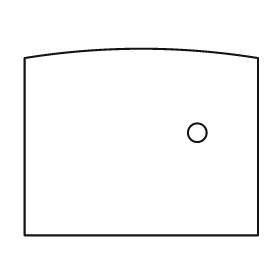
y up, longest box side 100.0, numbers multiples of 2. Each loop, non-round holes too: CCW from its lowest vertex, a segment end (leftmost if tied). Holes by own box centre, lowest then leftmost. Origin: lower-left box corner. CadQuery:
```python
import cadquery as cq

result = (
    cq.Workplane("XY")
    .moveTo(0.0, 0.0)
    .lineTo(100.0, 0.0)
    .lineTo(100.0, 76.0)
    .threePointArc((50.0, 80.0), (0.0, 76.0))
    .close()
    .moveTo(74.0, 44.0)
    .circle(4.0)
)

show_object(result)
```